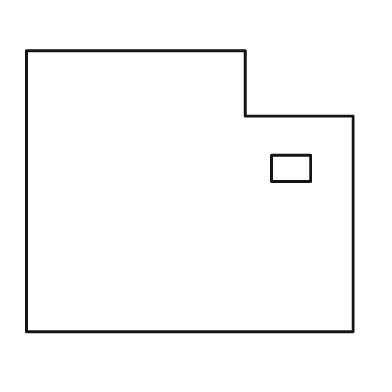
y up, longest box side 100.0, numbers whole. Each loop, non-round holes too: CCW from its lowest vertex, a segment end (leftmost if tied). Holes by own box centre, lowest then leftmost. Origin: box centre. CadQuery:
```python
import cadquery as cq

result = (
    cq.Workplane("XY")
    .moveTo(-50.0, -43.0)
    .lineTo(50.0, -43.0)
    .lineTo(50.0, 23.0)
    .lineTo(17.0, 23.0)
    .lineTo(17.0, 43.0)
    .lineTo(-50.0, 43.0)
    .close()
    .moveTo(25.0, 3.0)
    .lineTo(37.0, 3.0)
    .lineTo(37.0, 11.0)
    .lineTo(25.0, 11.0)
    .close()
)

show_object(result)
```